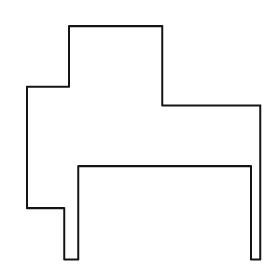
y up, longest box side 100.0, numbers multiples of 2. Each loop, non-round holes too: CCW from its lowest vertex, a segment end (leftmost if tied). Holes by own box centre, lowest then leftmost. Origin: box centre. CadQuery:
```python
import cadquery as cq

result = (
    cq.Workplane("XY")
    .moveTo(-34.0, -50.0)
    .lineTo(-28.0, -50.0)
    .lineTo(-28.0, -10.0)
    .lineTo(46.0, -10.0)
    .lineTo(46.0, -50.0)
    .lineTo(50.0, -50.0)
    .lineTo(50.0, 16.0)
    .lineTo(8.0, 16.0)
    .lineTo(8.0, 50.0)
    .lineTo(-32.0, 50.0)
    .lineTo(-32.0, 24.0)
    .lineTo(-50.0, 24.0)
    .lineTo(-50.0, -28.0)
    .lineTo(-34.0, -28.0)
    .close()
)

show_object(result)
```